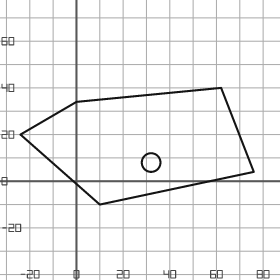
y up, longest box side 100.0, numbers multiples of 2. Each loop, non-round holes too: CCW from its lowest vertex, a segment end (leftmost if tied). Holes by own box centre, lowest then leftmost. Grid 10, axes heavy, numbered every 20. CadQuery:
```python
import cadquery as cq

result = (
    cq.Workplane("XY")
    .moveTo(10.0, -10.0)
    .lineTo(76.0, 4.0)
    .lineTo(62.0, 40.0)
    .lineTo(0.0, 34.0)
    .lineTo(-24.0, 20.0)
    .close()
    .moveTo(32.0, 8.0)
    .circle(4.0)
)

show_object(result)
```